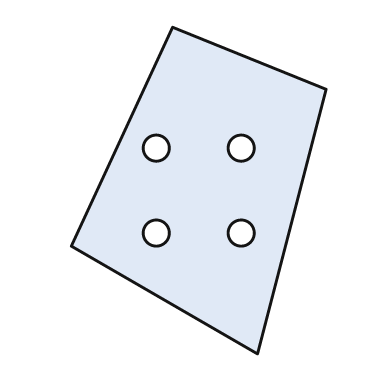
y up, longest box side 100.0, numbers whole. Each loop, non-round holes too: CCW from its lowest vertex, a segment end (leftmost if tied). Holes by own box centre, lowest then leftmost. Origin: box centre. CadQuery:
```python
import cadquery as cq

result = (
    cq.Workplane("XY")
    .moveTo(18.0, -50.0)
    .lineTo(39.0, 31.0)
    .lineTo(-8.0, 50.0)
    .lineTo(-39.0, -17.0)
    .close()
    .moveTo(-13.0, -13.0)
    .circle(4.0)
    .moveTo(13.0, -13.0)
    .circle(4.0)
    .moveTo(-13.0, 13.0)
    .circle(4.0)
    .moveTo(13.0, 13.0)
    .circle(4.0)
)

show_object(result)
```